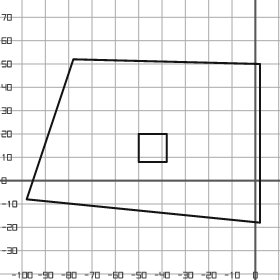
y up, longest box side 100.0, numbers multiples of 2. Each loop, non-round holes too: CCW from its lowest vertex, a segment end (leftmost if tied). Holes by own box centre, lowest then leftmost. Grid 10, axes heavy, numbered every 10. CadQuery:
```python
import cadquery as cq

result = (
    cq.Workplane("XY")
    .moveTo(2.0, -18.0)
    .lineTo(2.0, 50.0)
    .lineTo(-78.0, 52.0)
    .lineTo(-98.0, -8.0)
    .close()
    .moveTo(-50.0, 8.0)
    .lineTo(-38.0, 8.0)
    .lineTo(-38.0, 20.0)
    .lineTo(-50.0, 20.0)
    .close()
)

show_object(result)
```